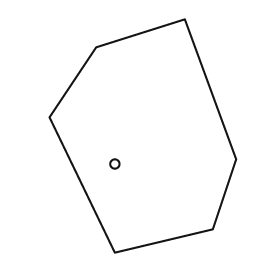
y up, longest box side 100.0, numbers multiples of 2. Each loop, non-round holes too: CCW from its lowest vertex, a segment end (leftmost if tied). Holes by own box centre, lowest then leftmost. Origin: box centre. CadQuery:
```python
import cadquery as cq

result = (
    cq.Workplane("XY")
    .moveTo(-12.0, -50.0)
    .lineTo(30.0, -40.0)
    .lineTo(40.0, -10.0)
    .lineTo(18.0, 50.0)
    .lineTo(-20.0, 38.0)
    .lineTo(-40.0, 8.0)
    .close()
    .moveTo(-12.0, -12.0)
    .circle(2.0)
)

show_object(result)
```